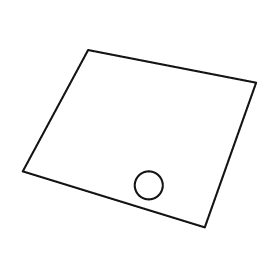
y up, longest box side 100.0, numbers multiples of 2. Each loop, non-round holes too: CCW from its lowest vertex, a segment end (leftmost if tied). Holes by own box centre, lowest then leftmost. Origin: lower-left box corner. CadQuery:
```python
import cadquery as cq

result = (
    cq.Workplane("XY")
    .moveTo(78.0, 0.0)
    .lineTo(100.0, 62.0)
    .lineTo(28.0, 76.0)
    .lineTo(0.0, 24.0)
    .close()
    .moveTo(54.0, 18.0)
    .circle(6.0)
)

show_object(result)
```